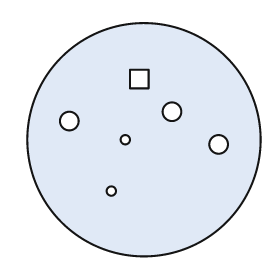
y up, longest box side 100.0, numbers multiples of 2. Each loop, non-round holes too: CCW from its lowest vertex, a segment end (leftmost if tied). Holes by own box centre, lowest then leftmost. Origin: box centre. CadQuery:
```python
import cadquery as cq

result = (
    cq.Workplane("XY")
    .moveTo(0.0, 0.0)
    .circle(50.0)
    .moveTo(-14.0, -22.0)
    .circle(2.0)
    .moveTo(32.0, -2.0)
    .circle(4.0)
    .moveTo(-8.0, 0.0)
    .circle(2.0)
    .moveTo(-32.0, 8.0)
    .circle(4.0)
    .moveTo(12.0, 12.0)
    .circle(4.0)
    .moveTo(-6.0, 22.0)
    .lineTo(2.0, 22.0)
    .lineTo(2.0, 30.0)
    .lineTo(-6.0, 30.0)
    .close()
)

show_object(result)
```